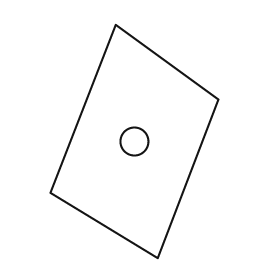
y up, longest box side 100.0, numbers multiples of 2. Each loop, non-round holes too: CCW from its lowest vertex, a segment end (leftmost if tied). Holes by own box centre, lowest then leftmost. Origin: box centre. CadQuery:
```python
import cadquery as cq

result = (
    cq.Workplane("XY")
    .moveTo(10.0, -50.0)
    .lineTo(36.0, 18.0)
    .lineTo(-8.0, 50.0)
    .lineTo(-36.0, -22.0)
    .close()
    .moveTo(0.0, 0.0)
    .circle(6.0)
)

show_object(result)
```